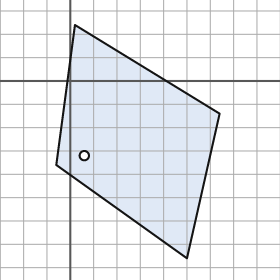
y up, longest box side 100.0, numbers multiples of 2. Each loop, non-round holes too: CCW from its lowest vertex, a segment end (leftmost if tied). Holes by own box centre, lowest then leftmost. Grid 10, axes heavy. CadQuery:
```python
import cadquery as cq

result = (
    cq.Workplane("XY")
    .moveTo(50.0, -76.0)
    .lineTo(64.0, -14.0)
    .lineTo(2.0, 24.0)
    .lineTo(-6.0, -36.0)
    .close()
    .moveTo(6.0, -32.0)
    .circle(2.0)
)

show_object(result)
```